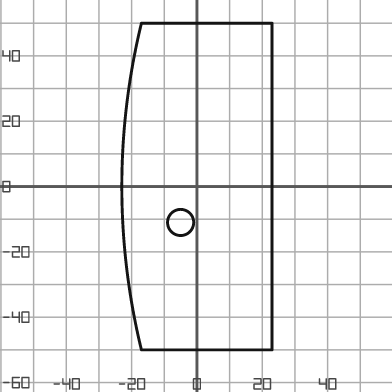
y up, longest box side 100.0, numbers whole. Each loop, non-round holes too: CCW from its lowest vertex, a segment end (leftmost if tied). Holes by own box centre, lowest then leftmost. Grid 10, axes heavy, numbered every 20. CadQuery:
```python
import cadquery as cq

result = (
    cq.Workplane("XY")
    .moveTo(-17.0, -50.0)
    .lineTo(23.0, -50.0)
    .lineTo(23.0, 50.0)
    .lineTo(-17.0, 50.0)
    .threePointArc((-23.0, 0.0), (-17.0, -50.0))
    .close()
    .moveTo(-5.0, -11.0)
    .circle(4.0)
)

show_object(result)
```